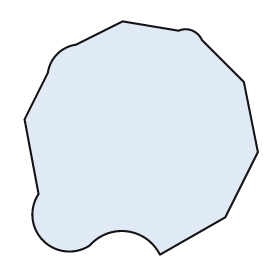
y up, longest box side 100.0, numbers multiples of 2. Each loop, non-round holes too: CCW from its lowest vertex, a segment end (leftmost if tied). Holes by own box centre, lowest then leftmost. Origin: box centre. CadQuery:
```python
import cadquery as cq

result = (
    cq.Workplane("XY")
    .moveTo(8.0, -50.0)
    .lineTo(36.0, -34.0)
    .lineTo(50.0, -6.0)
    .lineTo(44.0, 24.0)
    .lineTo(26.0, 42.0)
    .threePointArc((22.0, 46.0), (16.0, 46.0))
    .lineTo(-8.0, 50.0)
    .lineTo(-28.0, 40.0)
    .threePointArc((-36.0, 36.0), (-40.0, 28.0))
    .lineTo(-50.0, 8.0)
    .lineTo(-44.0, -24.0)
    .threePointArc((-42.0, -44.0), (-22.0, -46.0))
    .threePointArc((-6.0, -40.0), (8.0, -50.0))
    .close()
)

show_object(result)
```